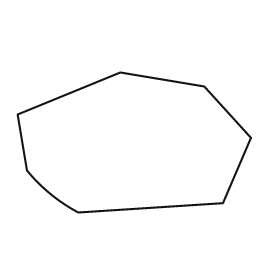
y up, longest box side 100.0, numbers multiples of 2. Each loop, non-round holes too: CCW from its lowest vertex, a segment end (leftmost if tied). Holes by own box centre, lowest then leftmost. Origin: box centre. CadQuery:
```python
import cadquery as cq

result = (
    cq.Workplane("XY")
    .moveTo(-24.0, -30.0)
    .lineTo(38.0, -26.0)
    .lineTo(50.0, 2.0)
    .lineTo(30.0, 24.0)
    .lineTo(-6.0, 30.0)
    .lineTo(-50.0, 12.0)
    .lineTo(-46.0, -12.0)
    .threePointArc((-36.0, -22.0), (-24.0, -30.0))
    .close()
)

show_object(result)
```